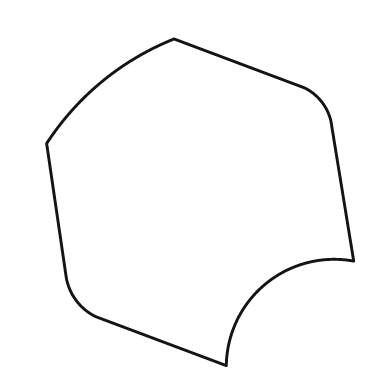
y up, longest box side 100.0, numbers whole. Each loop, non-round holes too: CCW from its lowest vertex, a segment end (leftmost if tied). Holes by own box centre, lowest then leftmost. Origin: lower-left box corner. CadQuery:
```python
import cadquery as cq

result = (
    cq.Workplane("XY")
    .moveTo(55.0, 0.0)
    .threePointArc((67.0, 25.0), (94.0, 32.0))
    .lineTo(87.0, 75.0)
    .threePointArc((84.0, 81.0), (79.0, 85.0))
    .lineTo(39.0, 100.0)
    .threePointArc((17.0, 87.0), (0.0, 68.0))
    .lineTo(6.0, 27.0)
    .threePointArc((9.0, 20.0), (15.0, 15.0))
    .close()
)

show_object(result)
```